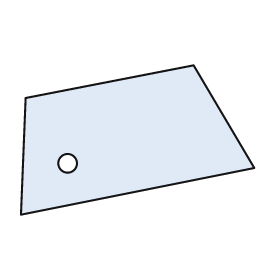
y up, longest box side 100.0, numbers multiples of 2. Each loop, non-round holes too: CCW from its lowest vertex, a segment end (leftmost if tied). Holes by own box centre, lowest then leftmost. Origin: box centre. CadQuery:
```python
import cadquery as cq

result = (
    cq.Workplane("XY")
    .moveTo(-50.0, -32.0)
    .lineTo(50.0, -12.0)
    .lineTo(24.0, 32.0)
    .lineTo(-48.0, 18.0)
    .close()
    .moveTo(-30.0, -10.0)
    .circle(4.0)
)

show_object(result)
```